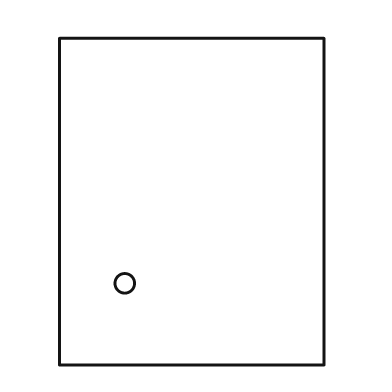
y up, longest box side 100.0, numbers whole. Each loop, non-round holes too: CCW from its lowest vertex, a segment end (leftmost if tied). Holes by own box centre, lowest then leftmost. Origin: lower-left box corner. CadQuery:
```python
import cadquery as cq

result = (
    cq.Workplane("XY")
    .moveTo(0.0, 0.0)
    .lineTo(81.0, 0.0)
    .lineTo(81.0, 100.0)
    .lineTo(0.0, 100.0)
    .close()
    .moveTo(20.0, 25.0)
    .circle(3.0)
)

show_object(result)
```